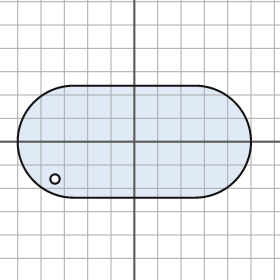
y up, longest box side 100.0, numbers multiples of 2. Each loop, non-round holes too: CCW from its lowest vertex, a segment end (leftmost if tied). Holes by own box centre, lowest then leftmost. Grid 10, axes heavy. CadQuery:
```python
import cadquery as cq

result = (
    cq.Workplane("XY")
    .moveTo(-26.0, -24.0)
    .lineTo(26.0, -24.0)
    .threePointArc((50.0, 0.0), (26.0, 24.0))
    .lineTo(-26.0, 24.0)
    .threePointArc((-50.0, 0.0), (-26.0, -24.0))
    .close()
    .moveTo(-34.0, -16.0)
    .circle(2.0)
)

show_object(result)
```